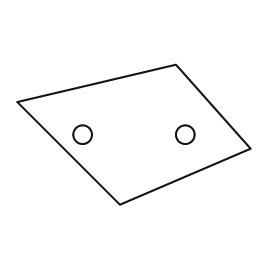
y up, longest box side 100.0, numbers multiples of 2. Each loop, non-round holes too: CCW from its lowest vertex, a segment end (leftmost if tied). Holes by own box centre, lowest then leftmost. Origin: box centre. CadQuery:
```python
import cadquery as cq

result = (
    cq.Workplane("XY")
    .moveTo(-6.0, -30.0)
    .lineTo(50.0, -6.0)
    .lineTo(18.0, 30.0)
    .lineTo(-50.0, 14.0)
    .close()
    .moveTo(-22.0, 0.0)
    .circle(4.0)
    .moveTo(22.0, 0.0)
    .circle(4.0)
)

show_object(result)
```